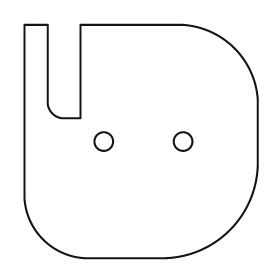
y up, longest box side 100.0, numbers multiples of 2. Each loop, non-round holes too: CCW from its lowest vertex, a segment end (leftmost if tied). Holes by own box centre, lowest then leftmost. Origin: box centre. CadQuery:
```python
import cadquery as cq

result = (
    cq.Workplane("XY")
    .moveTo(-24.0, -50.0)
    .lineTo(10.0, -50.0)
    .threePointArc((38.0, -38.0), (50.0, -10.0))
    .lineTo(50.0, 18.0)
    .threePointArc((40.0, 40.0), (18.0, 50.0))
    .lineTo(-26.0, 50.0)
    .lineTo(-26.0, 10.0)
    .lineTo(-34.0, 10.0)
    .threePointArc((-38.0, 12.0), (-40.0, 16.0))
    .lineTo(-40.0, 50.0)
    .lineTo(-50.0, 50.0)
    .lineTo(-50.0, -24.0)
    .threePointArc((-42.0, -42.0), (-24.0, -50.0))
    .close()
    .moveTo(-16.0, 0.0)
    .circle(4.0)
    .moveTo(18.0, 0.0)
    .circle(4.0)
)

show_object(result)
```